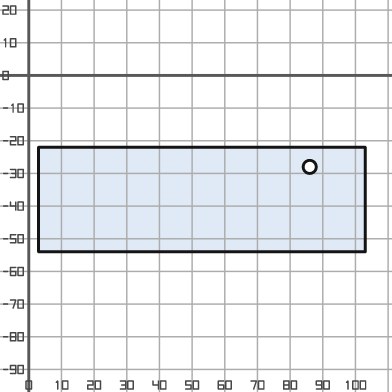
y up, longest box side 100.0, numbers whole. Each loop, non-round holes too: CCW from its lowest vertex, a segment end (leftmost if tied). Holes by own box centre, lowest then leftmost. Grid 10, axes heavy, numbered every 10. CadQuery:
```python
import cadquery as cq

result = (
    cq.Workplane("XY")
    .moveTo(3.0, -54.0)
    .lineTo(103.0, -54.0)
    .lineTo(103.0, -22.0)
    .lineTo(3.0, -22.0)
    .close()
    .moveTo(86.0, -28.0)
    .circle(2.0)
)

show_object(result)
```